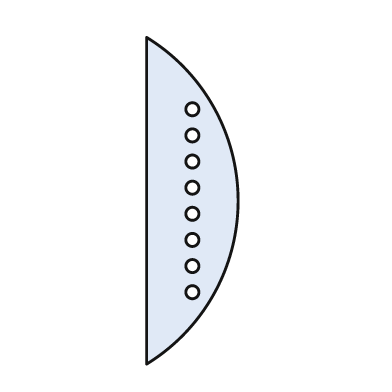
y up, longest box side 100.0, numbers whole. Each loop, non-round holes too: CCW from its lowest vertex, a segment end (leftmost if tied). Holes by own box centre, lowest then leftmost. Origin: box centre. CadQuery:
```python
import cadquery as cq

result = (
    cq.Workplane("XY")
    .moveTo(-14.0, -50.0)
    .threePointArc((14.0, 0.0), (-14.0, 50.0))
    .close()
    .moveTo(0.0, -28.0)
    .circle(2.0)
    .moveTo(0.0, -20.0)
    .circle(2.0)
    .moveTo(0.0, -12.0)
    .circle(2.0)
    .moveTo(0.0, -4.0)
    .circle(2.0)
    .moveTo(0.0, 4.0)
    .circle(2.0)
    .moveTo(0.0, 12.0)
    .circle(2.0)
    .moveTo(0.0, 20.0)
    .circle(2.0)
    .moveTo(0.0, 28.0)
    .circle(2.0)
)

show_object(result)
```